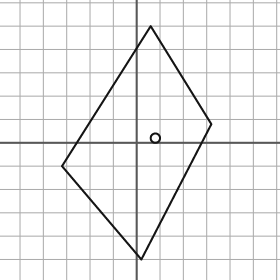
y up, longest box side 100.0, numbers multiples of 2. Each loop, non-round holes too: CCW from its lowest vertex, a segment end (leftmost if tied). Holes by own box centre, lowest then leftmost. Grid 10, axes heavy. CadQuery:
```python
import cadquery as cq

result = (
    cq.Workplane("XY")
    .moveTo(2.0, -50.0)
    .lineTo(32.0, 8.0)
    .lineTo(6.0, 50.0)
    .lineTo(-32.0, -10.0)
    .close()
    .moveTo(8.0, 2.0)
    .circle(2.0)
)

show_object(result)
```